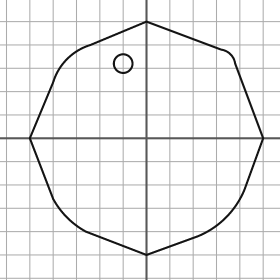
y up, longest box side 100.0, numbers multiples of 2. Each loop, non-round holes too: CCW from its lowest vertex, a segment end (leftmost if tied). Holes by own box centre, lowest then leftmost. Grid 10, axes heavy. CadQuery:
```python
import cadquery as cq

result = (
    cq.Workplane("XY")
    .moveTo(0.0, -50.0)
    .lineTo(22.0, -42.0)
    .threePointArc((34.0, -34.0), (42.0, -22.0))
    .lineTo(50.0, 0.0)
    .lineTo(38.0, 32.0)
    .threePointArc((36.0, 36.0), (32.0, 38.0))
    .lineTo(0.0, 50.0)
    .lineTo(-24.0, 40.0)
    .threePointArc((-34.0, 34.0), (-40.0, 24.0))
    .lineTo(-50.0, 0.0)
    .lineTo(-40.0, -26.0)
    .threePointArc((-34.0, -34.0), (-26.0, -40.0))
    .close()
    .moveTo(-10.0, 32.0)
    .circle(4.0)
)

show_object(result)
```